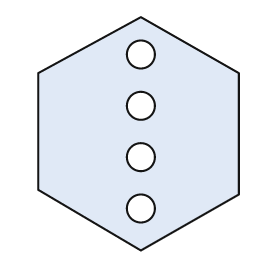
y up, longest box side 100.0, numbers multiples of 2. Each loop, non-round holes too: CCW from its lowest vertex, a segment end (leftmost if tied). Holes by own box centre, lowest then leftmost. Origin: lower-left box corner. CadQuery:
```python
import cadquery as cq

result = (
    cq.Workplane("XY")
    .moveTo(44.0, 0.0)
    .lineTo(86.0, 24.0)
    .lineTo(86.0, 76.0)
    .lineTo(44.0, 100.0)
    .lineTo(0.0, 76.0)
    .lineTo(0.0, 26.0)
    .close()
    .moveTo(44.0, 18.0)
    .circle(6.0)
    .moveTo(44.0, 40.0)
    .circle(6.0)
    .moveTo(44.0, 62.0)
    .circle(6.0)
    .moveTo(44.0, 84.0)
    .circle(6.0)
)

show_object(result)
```